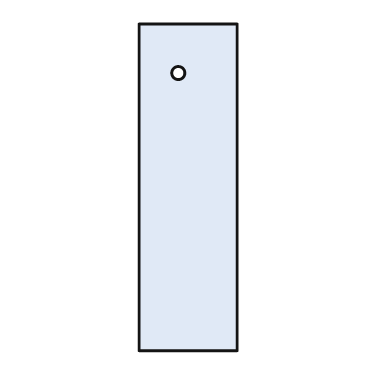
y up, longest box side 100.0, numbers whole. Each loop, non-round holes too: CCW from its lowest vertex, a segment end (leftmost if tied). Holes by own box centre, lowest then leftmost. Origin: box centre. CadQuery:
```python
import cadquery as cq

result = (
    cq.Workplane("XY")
    .moveTo(-15.0, -50.0)
    .lineTo(15.0, -50.0)
    .lineTo(15.0, 50.0)
    .lineTo(-15.0, 50.0)
    .close()
    .moveTo(-3.0, 35.0)
    .circle(2.0)
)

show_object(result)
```